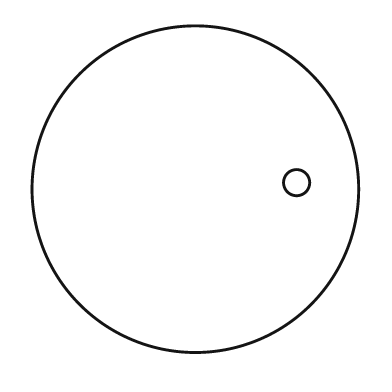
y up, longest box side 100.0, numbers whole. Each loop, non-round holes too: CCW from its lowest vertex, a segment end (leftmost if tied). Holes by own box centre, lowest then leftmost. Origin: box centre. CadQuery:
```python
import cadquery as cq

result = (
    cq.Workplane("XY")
    .moveTo(0.0, 0.0)
    .circle(50.0)
    .moveTo(31.0, 2.0)
    .circle(4.0)
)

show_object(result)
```